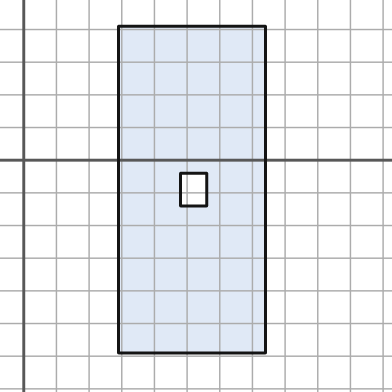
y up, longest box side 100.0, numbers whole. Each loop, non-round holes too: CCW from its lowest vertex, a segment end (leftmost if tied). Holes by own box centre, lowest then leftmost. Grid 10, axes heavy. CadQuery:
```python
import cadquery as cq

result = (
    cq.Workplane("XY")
    .moveTo(29.0, -59.0)
    .lineTo(74.0, -59.0)
    .lineTo(74.0, 41.0)
    .lineTo(29.0, 41.0)
    .close()
    .moveTo(48.0, -14.0)
    .lineTo(56.0, -14.0)
    .lineTo(56.0, -4.0)
    .lineTo(48.0, -4.0)
    .close()
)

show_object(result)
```